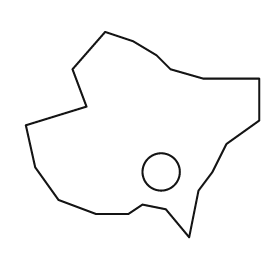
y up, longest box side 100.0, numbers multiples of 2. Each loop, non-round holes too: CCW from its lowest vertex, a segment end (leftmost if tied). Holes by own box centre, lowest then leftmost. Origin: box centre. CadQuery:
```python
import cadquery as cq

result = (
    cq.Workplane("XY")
    .moveTo(20.0, -44.0)
    .lineTo(24.0, -24.0)
    .lineTo(30.0, -16.0)
    .lineTo(36.0, -4.0)
    .lineTo(50.0, 6.0)
    .lineTo(50.0, 24.0)
    .lineTo(26.0, 24.0)
    .lineTo(12.0, 28.0)
    .lineTo(6.0, 34.0)
    .lineTo(-4.0, 40.0)
    .lineTo(-16.0, 44.0)
    .lineTo(-30.0, 28.0)
    .lineTo(-24.0, 12.0)
    .lineTo(-50.0, 4.0)
    .lineTo(-46.0, -14.0)
    .lineTo(-36.0, -28.0)
    .lineTo(-20.0, -34.0)
    .lineTo(-6.0, -34.0)
    .lineTo(0.0, -30.0)
    .lineTo(10.0, -32.0)
    .close()
    .moveTo(8.0, -16.0)
    .circle(8.0)
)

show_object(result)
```